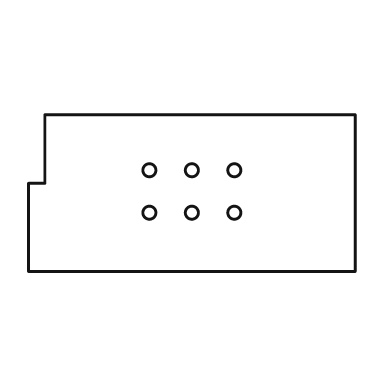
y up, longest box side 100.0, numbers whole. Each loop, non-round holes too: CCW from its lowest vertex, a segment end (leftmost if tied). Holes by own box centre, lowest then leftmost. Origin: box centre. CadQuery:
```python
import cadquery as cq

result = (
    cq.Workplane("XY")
    .moveTo(-50.0, -24.0)
    .lineTo(50.0, -24.0)
    .lineTo(50.0, 24.0)
    .lineTo(-45.0, 24.0)
    .lineTo(-45.0, 3.0)
    .lineTo(-50.0, 3.0)
    .close()
    .moveTo(-13.0, -6.0)
    .circle(2.0)
    .moveTo(0.0, -6.0)
    .circle(2.0)
    .moveTo(13.0, -6.0)
    .circle(2.0)
    .moveTo(-13.0, 7.0)
    .circle(2.0)
    .moveTo(0.0, 7.0)
    .circle(2.0)
    .moveTo(13.0, 7.0)
    .circle(2.0)
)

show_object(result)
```